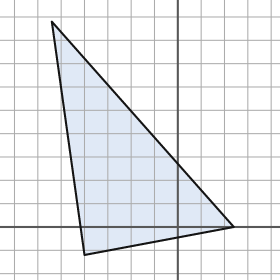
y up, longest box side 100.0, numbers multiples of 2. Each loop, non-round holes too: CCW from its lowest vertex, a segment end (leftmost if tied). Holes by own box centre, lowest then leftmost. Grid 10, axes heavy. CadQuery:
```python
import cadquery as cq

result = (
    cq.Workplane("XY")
    .moveTo(-40.0, -12.0)
    .lineTo(24.0, 0.0)
    .lineTo(-54.0, 88.0)
    .close()
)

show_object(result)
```